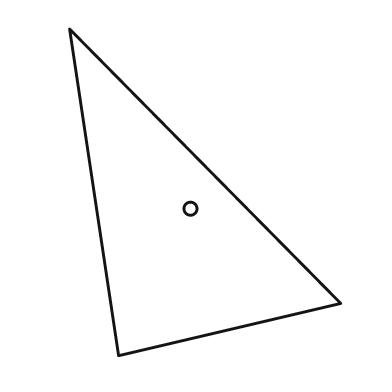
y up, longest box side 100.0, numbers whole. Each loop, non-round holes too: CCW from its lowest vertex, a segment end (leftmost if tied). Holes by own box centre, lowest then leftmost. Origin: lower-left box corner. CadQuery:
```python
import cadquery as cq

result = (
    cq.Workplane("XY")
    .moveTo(15.0, 0.0)
    .lineTo(83.0, 16.0)
    .lineTo(0.0, 100.0)
    .close()
    .moveTo(37.0, 45.0)
    .circle(2.0)
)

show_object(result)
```